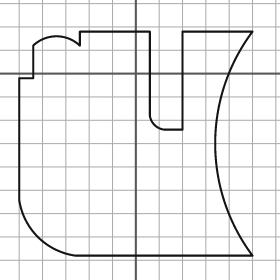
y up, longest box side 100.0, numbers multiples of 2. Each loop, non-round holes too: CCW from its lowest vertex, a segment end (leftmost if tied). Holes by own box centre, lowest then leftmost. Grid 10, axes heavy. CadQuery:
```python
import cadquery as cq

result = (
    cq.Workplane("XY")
    .moveTo(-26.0, -78.0)
    .lineTo(50.0, -78.0)
    .threePointArc((34.0, -30.0), (50.0, 18.0))
    .lineTo(20.0, 18.0)
    .lineTo(20.0, -24.0)
    .lineTo(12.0, -24.0)
    .threePointArc((8.0, -22.0), (6.0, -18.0))
    .lineTo(6.0, 18.0)
    .lineTo(-24.0, 18.0)
    .lineTo(-24.0, 12.0)
    .threePointArc((-34.0, 16.0), (-44.0, 12.0))
    .lineTo(-44.0, -2.0)
    .lineTo(-50.0, -2.0)
    .lineTo(-50.0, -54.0)
    .threePointArc((-42.0, -70.0), (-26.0, -78.0))
    .close()
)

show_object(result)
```